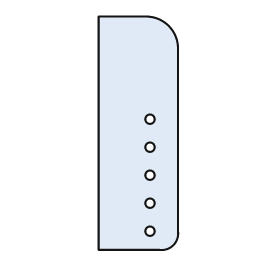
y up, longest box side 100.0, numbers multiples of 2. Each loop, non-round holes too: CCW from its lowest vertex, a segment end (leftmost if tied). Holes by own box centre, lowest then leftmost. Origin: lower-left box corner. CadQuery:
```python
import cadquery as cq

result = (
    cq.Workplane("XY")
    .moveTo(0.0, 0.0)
    .lineTo(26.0, 0.0)
    .threePointArc((32.0, 2.0), (34.0, 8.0))
    .lineTo(34.0, 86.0)
    .threePointArc((30.0, 96.0), (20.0, 100.0))
    .lineTo(0.0, 100.0)
    .close()
    .moveTo(22.0, 8.0)
    .circle(2.0)
    .moveTo(22.0, 20.0)
    .circle(2.0)
    .moveTo(22.0, 32.0)
    .circle(2.0)
    .moveTo(22.0, 44.0)
    .circle(2.0)
    .moveTo(22.0, 56.0)
    .circle(2.0)
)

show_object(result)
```